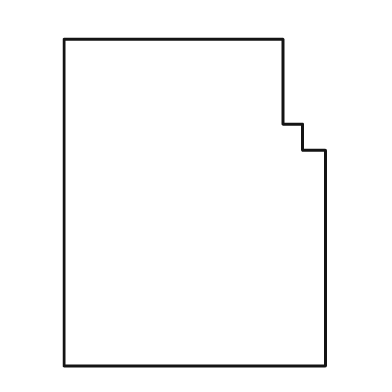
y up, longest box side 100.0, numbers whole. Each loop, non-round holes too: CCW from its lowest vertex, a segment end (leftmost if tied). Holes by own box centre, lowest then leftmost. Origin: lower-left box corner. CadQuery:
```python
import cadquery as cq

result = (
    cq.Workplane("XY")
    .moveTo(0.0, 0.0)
    .lineTo(80.0, 0.0)
    .lineTo(80.0, 66.0)
    .lineTo(73.0, 66.0)
    .lineTo(73.0, 74.0)
    .lineTo(67.0, 74.0)
    .lineTo(67.0, 100.0)
    .lineTo(0.0, 100.0)
    .close()
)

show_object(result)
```